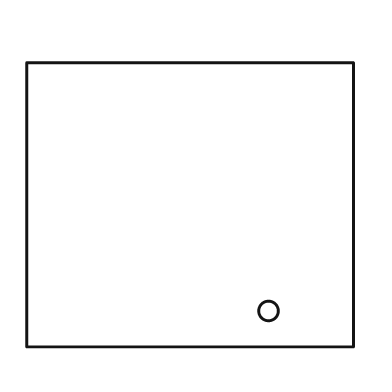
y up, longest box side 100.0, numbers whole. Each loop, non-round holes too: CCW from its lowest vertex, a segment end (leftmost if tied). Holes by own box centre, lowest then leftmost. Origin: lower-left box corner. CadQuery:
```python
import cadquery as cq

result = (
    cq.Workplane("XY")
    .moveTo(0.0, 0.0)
    .lineTo(100.0, 0.0)
    .lineTo(100.0, 87.0)
    .lineTo(0.0, 87.0)
    .close()
    .moveTo(74.0, 11.0)
    .circle(3.0)
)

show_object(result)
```